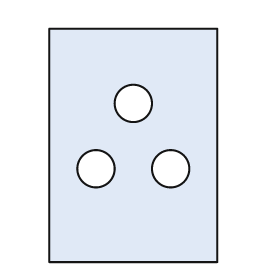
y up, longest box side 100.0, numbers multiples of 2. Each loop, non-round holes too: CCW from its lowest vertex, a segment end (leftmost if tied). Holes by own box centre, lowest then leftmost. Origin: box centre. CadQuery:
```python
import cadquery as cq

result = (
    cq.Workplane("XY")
    .moveTo(-36.0, -50.0)
    .lineTo(36.0, -50.0)
    .lineTo(36.0, 50.0)
    .lineTo(-36.0, 50.0)
    .close()
    .moveTo(-16.0, -10.0)
    .circle(8.0)
    .moveTo(16.0, -10.0)
    .circle(8.0)
    .moveTo(0.0, 18.0)
    .circle(8.0)
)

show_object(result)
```